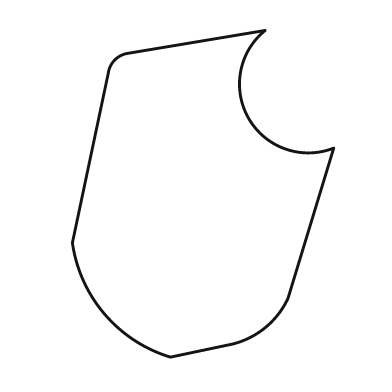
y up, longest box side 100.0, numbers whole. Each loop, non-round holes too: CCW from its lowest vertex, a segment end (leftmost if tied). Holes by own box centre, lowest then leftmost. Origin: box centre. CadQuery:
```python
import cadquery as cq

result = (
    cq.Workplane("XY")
    .moveTo(-10.0, -50.0)
    .lineTo(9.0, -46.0)
    .threePointArc((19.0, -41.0), (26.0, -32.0))
    .lineTo(40.0, 14.0)
    .threePointArc((14.0, 23.0), (19.0, 50.0))
    .lineTo(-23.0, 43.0)
    .threePointArc((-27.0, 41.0), (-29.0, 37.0))
    .lineTo(-40.0, -15.0)
    .threePointArc((-30.0, -37.0), (-10.0, -50.0))
    .close()
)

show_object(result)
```